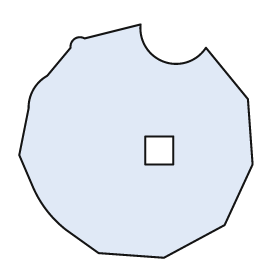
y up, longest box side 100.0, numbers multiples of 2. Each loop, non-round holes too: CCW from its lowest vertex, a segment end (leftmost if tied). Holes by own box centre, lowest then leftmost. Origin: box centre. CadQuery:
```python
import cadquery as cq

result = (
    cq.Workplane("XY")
    .moveTo(12.0, -50.0)
    .lineTo(38.0, -36.0)
    .lineTo(50.0, -10.0)
    .lineTo(48.0, 18.0)
    .lineTo(30.0, 40.0)
    .threePointArc((12.0, 34.0), (2.0, 50.0))
    .lineTo(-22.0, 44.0)
    .threePointArc((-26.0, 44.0), (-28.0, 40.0))
    .lineTo(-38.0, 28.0)
    .threePointArc((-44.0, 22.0), (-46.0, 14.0))
    .lineTo(-50.0, -6.0)
    .lineTo(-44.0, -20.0)
    .threePointArc((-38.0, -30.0), (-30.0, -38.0))
    .lineTo(-16.0, -48.0)
    .close()
    .moveTo(4.0, -10.0)
    .lineTo(16.0, -10.0)
    .lineTo(16.0, 2.0)
    .lineTo(4.0, 2.0)
    .close()
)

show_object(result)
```